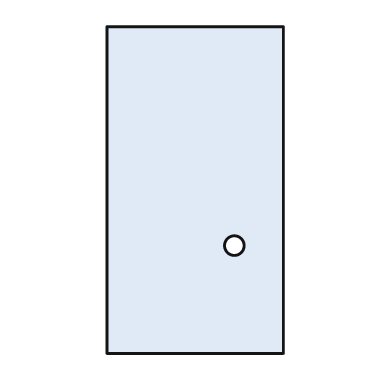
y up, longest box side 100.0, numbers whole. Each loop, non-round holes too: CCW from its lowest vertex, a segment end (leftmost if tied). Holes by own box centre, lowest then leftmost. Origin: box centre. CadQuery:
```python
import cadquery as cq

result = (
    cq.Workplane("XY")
    .moveTo(-27.0, -50.0)
    .lineTo(27.0, -50.0)
    .lineTo(27.0, 50.0)
    .lineTo(-27.0, 50.0)
    .close()
    .moveTo(12.0, -17.0)
    .circle(3.0)
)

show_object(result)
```